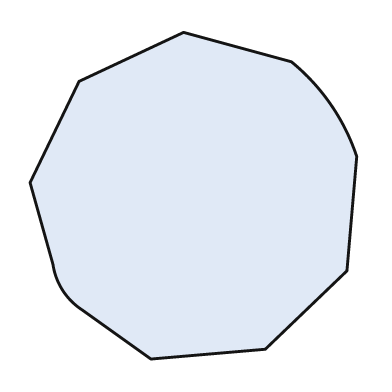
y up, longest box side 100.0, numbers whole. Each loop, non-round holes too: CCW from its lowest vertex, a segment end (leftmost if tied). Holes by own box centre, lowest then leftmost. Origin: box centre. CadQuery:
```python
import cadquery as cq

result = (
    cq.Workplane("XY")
    .moveTo(-13.0, -50.0)
    .lineTo(22.0, -47.0)
    .lineTo(47.0, -23.0)
    .lineTo(50.0, 12.0)
    .threePointArc((42.0, 28.0), (30.0, 41.0))
    .lineTo(-3.0, 50.0)
    .lineTo(-35.0, 35.0)
    .lineTo(-50.0, 4.0)
    .lineTo(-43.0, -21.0)
    .threePointArc((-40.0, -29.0), (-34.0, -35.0))
    .close()
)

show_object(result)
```